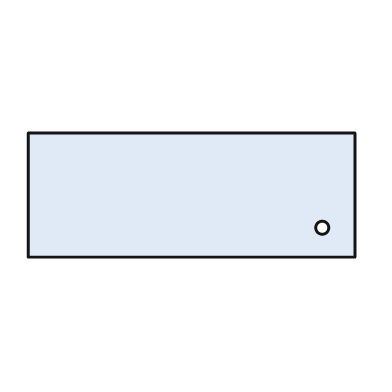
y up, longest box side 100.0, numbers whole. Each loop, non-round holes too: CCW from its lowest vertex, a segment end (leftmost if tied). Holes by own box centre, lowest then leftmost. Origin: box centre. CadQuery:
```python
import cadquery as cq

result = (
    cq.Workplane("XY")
    .moveTo(-50.0, -19.0)
    .lineTo(50.0, -19.0)
    .lineTo(50.0, 19.0)
    .lineTo(-50.0, 19.0)
    .close()
    .moveTo(40.0, -10.0)
    .circle(2.0)
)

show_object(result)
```